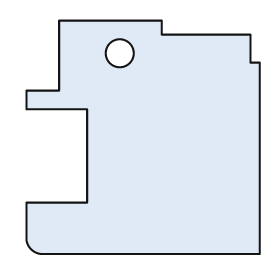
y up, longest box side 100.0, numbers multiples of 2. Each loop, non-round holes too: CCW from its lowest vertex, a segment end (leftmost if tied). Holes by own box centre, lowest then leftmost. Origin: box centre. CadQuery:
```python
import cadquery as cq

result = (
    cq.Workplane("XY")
    .moveTo(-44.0, -50.0)
    .lineTo(50.0, -50.0)
    .lineTo(50.0, 32.0)
    .lineTo(46.0, 32.0)
    .lineTo(46.0, 44.0)
    .lineTo(8.0, 44.0)
    .lineTo(8.0, 50.0)
    .lineTo(-36.0, 50.0)
    .lineTo(-36.0, 20.0)
    .lineTo(-50.0, 20.0)
    .lineTo(-50.0, 12.0)
    .lineTo(-24.0, 12.0)
    .lineTo(-24.0, -28.0)
    .lineTo(-50.0, -28.0)
    .lineTo(-50.0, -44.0)
    .threePointArc((-48.0, -48.0), (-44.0, -50.0))
    .close()
    .moveTo(-10.0, 36.0)
    .circle(6.0)
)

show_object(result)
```